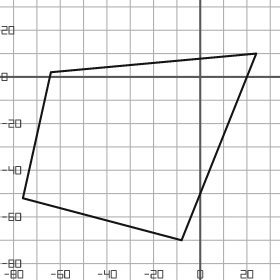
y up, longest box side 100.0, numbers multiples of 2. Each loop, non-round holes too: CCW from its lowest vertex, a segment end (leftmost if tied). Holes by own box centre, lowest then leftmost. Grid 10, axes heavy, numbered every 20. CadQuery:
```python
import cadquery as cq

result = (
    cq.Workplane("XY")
    .moveTo(-8.0, -70.0)
    .lineTo(24.0, 10.0)
    .lineTo(-64.0, 2.0)
    .lineTo(-76.0, -52.0)
    .close()
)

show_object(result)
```